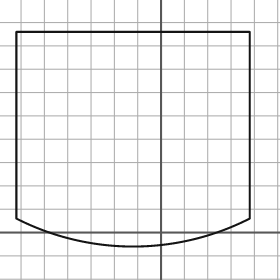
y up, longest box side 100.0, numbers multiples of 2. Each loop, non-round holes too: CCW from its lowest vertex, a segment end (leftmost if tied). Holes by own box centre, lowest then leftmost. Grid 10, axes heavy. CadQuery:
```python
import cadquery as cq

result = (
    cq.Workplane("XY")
    .moveTo(-62.0, 6.0)
    .threePointArc((-12.0, -6.0), (38.0, 6.0))
    .lineTo(38.0, 86.0)
    .lineTo(-62.0, 86.0)
    .close()
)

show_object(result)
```